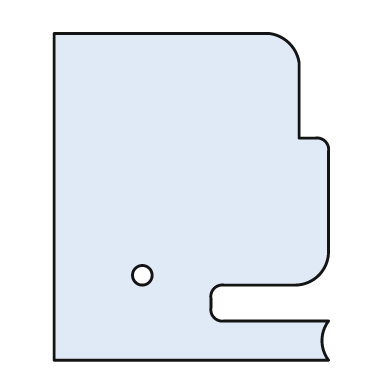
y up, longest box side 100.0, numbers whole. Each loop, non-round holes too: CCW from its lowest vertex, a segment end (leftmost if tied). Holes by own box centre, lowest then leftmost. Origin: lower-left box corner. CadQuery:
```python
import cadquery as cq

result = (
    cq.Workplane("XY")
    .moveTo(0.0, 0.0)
    .lineTo(84.0, 0.0)
    .threePointArc((82.0, 6.0), (84.0, 12.0))
    .lineTo(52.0, 12.0)
    .threePointArc((49.0, 13.0), (48.0, 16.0))
    .lineTo(48.0, 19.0)
    .threePointArc((49.0, 22.0), (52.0, 23.0))
    .lineTo(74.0, 23.0)
    .threePointArc((81.0, 26.0), (84.0, 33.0))
    .lineTo(84.0, 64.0)
    .threePointArc((83.0, 67.0), (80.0, 68.0))
    .lineTo(75.0, 68.0)
    .lineTo(75.0, 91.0)
    .threePointArc((72.0, 97.0), (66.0, 100.0))
    .lineTo(0.0, 100.0)
    .close()
    .moveTo(27.0, 26.0)
    .circle(3.0)
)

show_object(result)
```